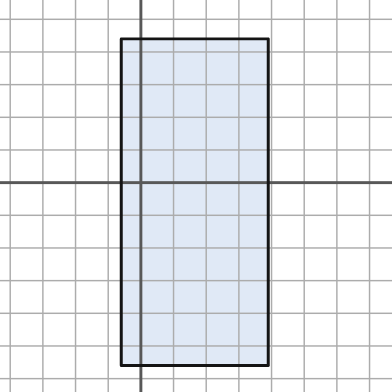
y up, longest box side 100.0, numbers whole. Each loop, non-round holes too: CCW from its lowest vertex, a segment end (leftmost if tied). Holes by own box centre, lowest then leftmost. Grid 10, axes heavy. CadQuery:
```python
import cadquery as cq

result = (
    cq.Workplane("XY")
    .moveTo(-6.0, -56.0)
    .lineTo(39.0, -56.0)
    .lineTo(39.0, 44.0)
    .lineTo(-6.0, 44.0)
    .close()
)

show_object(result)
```